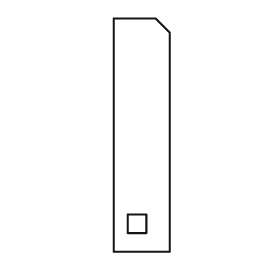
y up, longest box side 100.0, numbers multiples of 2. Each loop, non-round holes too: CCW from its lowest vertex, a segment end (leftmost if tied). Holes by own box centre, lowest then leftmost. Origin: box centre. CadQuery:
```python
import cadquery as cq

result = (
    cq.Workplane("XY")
    .moveTo(-12.0, -50.0)
    .lineTo(12.0, -50.0)
    .lineTo(12.0, 44.0)
    .lineTo(6.0, 50.0)
    .lineTo(-12.0, 50.0)
    .close()
    .moveTo(-6.0, -42.0)
    .lineTo(2.0, -42.0)
    .lineTo(2.0, -34.0)
    .lineTo(-6.0, -34.0)
    .close()
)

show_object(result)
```